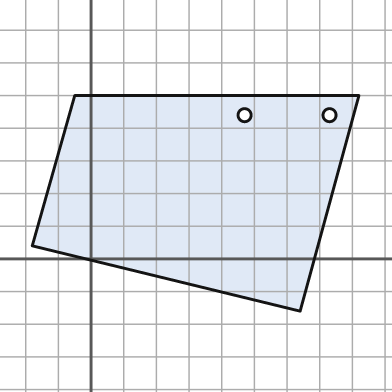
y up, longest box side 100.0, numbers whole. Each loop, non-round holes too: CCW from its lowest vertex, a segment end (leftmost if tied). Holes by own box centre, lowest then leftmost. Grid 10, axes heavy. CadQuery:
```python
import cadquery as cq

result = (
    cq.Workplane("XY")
    .moveTo(64.0, -16.0)
    .lineTo(82.0, 50.0)
    .lineTo(-5.0, 50.0)
    .lineTo(-18.0, 4.0)
    .close()
    .moveTo(47.0, 44.0)
    .circle(2.0)
    .moveTo(73.0, 44.0)
    .circle(2.0)
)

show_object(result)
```